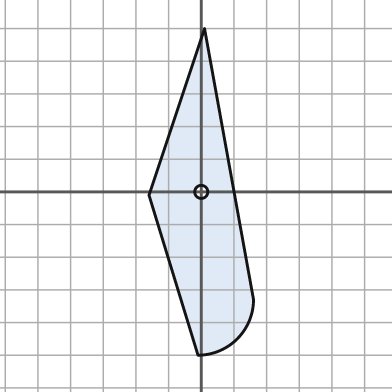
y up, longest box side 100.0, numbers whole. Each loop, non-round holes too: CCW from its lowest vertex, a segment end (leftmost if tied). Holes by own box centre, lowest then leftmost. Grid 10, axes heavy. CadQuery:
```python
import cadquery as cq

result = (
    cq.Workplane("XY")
    .moveTo(-1.0, -50.0)
    .threePointArc((11.0, -45.0), (16.0, -33.0))
    .lineTo(1.0, 50.0)
    .lineTo(-16.0, -1.0)
    .close()
    .moveTo(0.0, 0.0)
    .circle(2.0)
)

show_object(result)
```